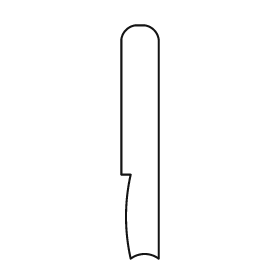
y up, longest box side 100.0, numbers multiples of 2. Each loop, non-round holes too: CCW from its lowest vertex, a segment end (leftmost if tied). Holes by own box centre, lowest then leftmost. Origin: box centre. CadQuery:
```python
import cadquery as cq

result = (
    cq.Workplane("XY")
    .moveTo(-4.0, -50.0)
    .threePointArc((2.0, -48.0), (8.0, -50.0))
    .lineTo(8.0, 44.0)
    .threePointArc((6.0, 48.0), (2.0, 50.0))
    .lineTo(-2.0, 50.0)
    .threePointArc((-6.0, 48.0), (-8.0, 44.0))
    .lineTo(-8.0, -14.0)
    .lineTo(-4.0, -14.0)
    .threePointArc((-6.0, -32.0), (-4.0, -50.0))
    .close()
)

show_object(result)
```